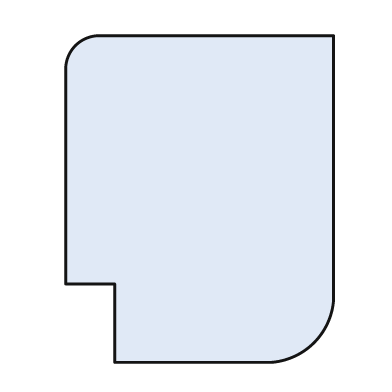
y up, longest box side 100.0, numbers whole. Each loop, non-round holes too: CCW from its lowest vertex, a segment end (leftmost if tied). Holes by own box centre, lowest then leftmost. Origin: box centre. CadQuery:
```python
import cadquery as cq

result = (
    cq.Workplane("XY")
    .moveTo(-26.0, -50.0)
    .lineTo(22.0, -50.0)
    .threePointArc((35.0, -44.0), (41.0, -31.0))
    .lineTo(41.0, 50.0)
    .lineTo(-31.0, 50.0)
    .threePointArc((-38.0, 47.0), (-41.0, 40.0))
    .lineTo(-41.0, -26.0)
    .lineTo(-26.0, -26.0)
    .close()
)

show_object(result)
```